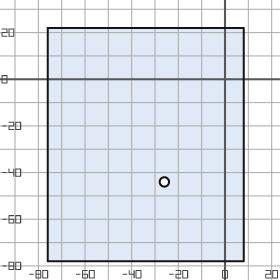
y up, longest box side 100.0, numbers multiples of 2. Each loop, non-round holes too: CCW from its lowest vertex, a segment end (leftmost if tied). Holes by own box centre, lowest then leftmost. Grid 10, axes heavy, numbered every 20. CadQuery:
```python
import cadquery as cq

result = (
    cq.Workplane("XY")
    .moveTo(-76.0, -78.0)
    .lineTo(8.0, -78.0)
    .lineTo(8.0, 22.0)
    .lineTo(-76.0, 22.0)
    .close()
    .moveTo(-26.0, -44.0)
    .circle(2.0)
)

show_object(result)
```